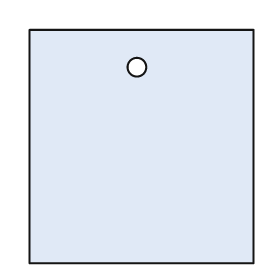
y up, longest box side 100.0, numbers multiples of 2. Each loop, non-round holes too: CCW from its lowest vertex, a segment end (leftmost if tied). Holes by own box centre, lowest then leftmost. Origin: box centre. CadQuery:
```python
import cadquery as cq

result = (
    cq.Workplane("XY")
    .moveTo(-48.0, -50.0)
    .lineTo(48.0, -50.0)
    .lineTo(48.0, 50.0)
    .lineTo(-48.0, 50.0)
    .close()
    .moveTo(-2.0, 34.0)
    .circle(4.0)
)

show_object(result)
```